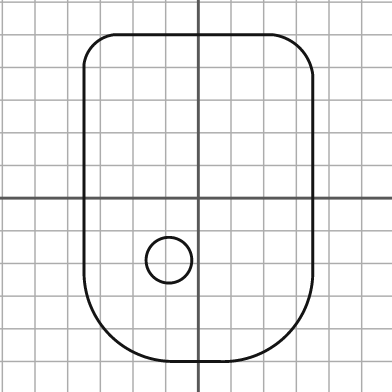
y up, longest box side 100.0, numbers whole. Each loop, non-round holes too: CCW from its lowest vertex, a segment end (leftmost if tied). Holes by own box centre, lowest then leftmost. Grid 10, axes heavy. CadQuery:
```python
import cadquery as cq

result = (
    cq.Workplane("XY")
    .moveTo(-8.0, -50.0)
    .lineTo(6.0, -50.0)
    .threePointArc((27.0, -42.0), (35.0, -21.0))
    .lineTo(35.0, 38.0)
    .threePointArc((31.0, 46.0), (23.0, 50.0))
    .lineTo(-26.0, 50.0)
    .threePointArc((-32.0, 47.0), (-35.0, 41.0))
    .lineTo(-35.0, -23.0)
    .threePointArc((-27.0, -42.0), (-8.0, -50.0))
    .close()
    .moveTo(-9.0, -19.0)
    .circle(7.0)
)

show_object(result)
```